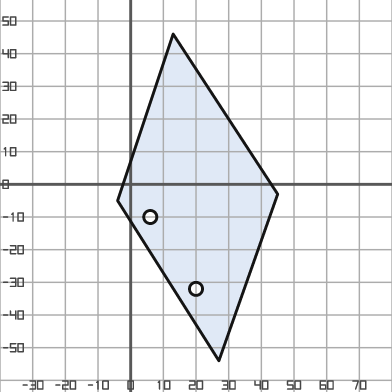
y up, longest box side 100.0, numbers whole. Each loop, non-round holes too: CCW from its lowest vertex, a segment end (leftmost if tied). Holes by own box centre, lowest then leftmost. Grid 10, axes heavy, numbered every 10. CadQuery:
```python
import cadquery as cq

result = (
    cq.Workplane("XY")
    .moveTo(27.0, -54.0)
    .lineTo(45.0, -3.0)
    .lineTo(13.0, 46.0)
    .lineTo(-4.0, -5.0)
    .close()
    .moveTo(20.0, -32.0)
    .circle(2.0)
    .moveTo(6.0, -10.0)
    .circle(2.0)
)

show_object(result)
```